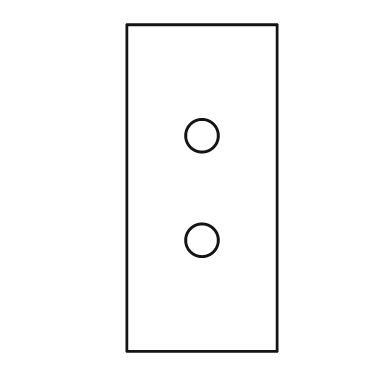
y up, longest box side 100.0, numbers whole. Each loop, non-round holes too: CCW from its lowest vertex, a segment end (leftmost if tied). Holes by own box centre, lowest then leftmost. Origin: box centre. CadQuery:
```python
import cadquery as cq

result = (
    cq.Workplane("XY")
    .moveTo(-23.0, -50.0)
    .lineTo(23.0, -50.0)
    .lineTo(23.0, 50.0)
    .lineTo(-23.0, 50.0)
    .close()
    .moveTo(0.0, -16.0)
    .circle(5.0)
    .moveTo(0.0, 16.0)
    .circle(5.0)
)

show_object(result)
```